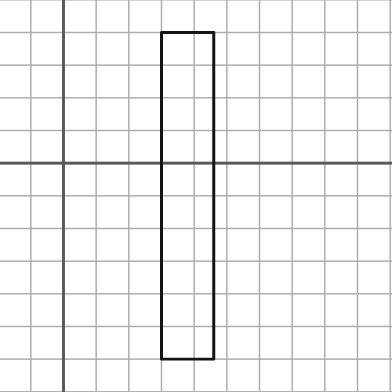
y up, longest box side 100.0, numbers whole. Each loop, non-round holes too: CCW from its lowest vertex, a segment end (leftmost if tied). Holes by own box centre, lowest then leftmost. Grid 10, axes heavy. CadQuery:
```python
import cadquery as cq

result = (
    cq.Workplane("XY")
    .moveTo(30.0, -60.0)
    .lineTo(46.0, -60.0)
    .lineTo(46.0, 40.0)
    .lineTo(30.0, 40.0)
    .close()
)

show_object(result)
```